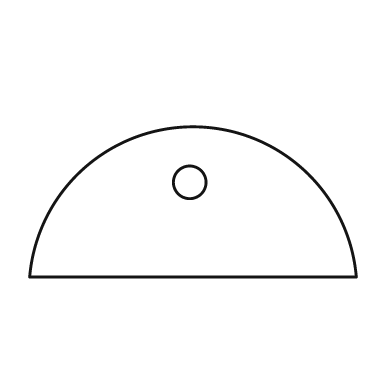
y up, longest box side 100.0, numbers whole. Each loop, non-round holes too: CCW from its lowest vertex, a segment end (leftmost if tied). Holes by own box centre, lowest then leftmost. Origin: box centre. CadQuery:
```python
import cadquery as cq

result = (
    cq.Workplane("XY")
    .moveTo(-50.0, -23.0)
    .lineTo(50.0, -23.0)
    .threePointArc((0.0, 23.0), (-50.0, -23.0))
    .close()
    .moveTo(-1.0, 6.0)
    .circle(5.0)
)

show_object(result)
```